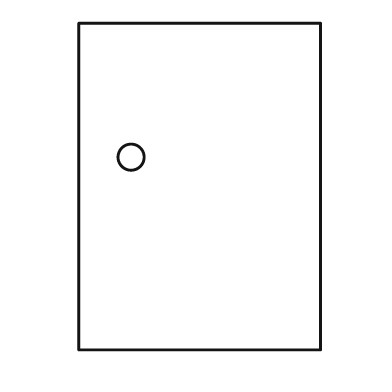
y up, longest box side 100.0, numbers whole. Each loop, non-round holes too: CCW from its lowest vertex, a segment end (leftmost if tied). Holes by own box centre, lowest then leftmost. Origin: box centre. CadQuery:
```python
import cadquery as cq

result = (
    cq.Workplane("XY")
    .moveTo(-37.0, -50.0)
    .lineTo(37.0, -50.0)
    .lineTo(37.0, 50.0)
    .lineTo(-37.0, 50.0)
    .close()
    .moveTo(-21.0, 9.0)
    .circle(4.0)
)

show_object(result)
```